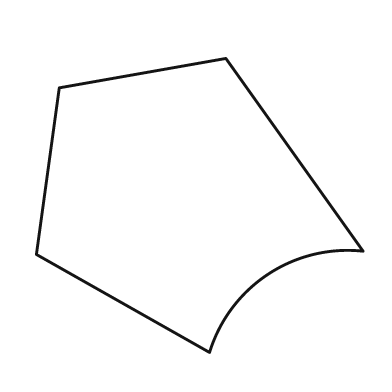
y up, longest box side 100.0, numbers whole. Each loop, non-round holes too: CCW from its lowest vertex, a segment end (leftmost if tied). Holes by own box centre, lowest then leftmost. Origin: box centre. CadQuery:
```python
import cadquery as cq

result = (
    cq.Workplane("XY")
    .moveTo(3.0, -45.0)
    .threePointArc((21.0, -21.0), (50.0, -14.0))
    .lineTo(8.0, 45.0)
    .lineTo(-43.0, 36.0)
    .lineTo(-50.0, -15.0)
    .close()
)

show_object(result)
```